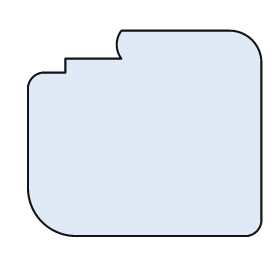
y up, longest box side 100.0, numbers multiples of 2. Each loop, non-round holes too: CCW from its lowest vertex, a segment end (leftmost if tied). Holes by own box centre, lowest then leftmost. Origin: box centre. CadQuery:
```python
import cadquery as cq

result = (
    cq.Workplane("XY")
    .moveTo(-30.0, -44.0)
    .lineTo(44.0, -44.0)
    .threePointArc((48.0, -42.0), (50.0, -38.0))
    .lineTo(50.0, 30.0)
    .threePointArc((46.0, 40.0), (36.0, 44.0))
    .lineTo(-10.0, 44.0)
    .threePointArc((-12.0, 38.0), (-10.0, 32.0))
    .lineTo(-34.0, 32.0)
    .lineTo(-34.0, 26.0)
    .lineTo(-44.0, 26.0)
    .threePointArc((-48.0, 24.0), (-50.0, 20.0))
    .lineTo(-50.0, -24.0)
    .threePointArc((-44.0, -38.0), (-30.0, -44.0))
    .close()
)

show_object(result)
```